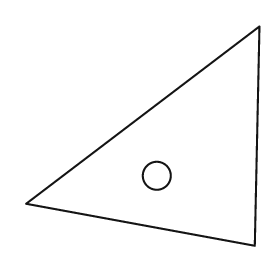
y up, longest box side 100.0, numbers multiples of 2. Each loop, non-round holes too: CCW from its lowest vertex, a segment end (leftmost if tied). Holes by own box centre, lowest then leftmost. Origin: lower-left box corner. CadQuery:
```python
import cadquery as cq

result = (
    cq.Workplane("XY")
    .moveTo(98.0, 0.0)
    .lineTo(100.0, 94.0)
    .lineTo(0.0, 18.0)
    .close()
    .moveTo(56.0, 30.0)
    .circle(6.0)
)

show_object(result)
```